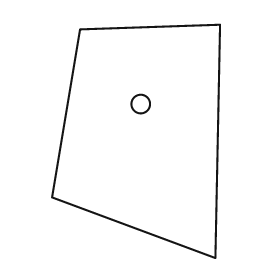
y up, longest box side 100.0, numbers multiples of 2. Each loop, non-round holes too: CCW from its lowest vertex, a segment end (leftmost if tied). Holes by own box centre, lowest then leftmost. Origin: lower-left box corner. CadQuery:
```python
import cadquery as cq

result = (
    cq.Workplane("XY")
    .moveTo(70.0, 0.0)
    .lineTo(72.0, 100.0)
    .lineTo(12.0, 98.0)
    .lineTo(0.0, 26.0)
    .close()
    .moveTo(38.0, 66.0)
    .circle(4.0)
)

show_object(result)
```